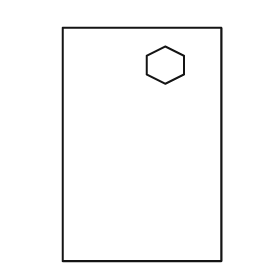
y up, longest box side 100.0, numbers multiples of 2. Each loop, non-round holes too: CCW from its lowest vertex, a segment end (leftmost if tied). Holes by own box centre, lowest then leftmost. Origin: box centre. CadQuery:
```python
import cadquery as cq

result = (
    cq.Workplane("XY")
    .moveTo(-34.0, -50.0)
    .lineTo(34.0, -50.0)
    .lineTo(34.0, 50.0)
    .lineTo(-34.0, 50.0)
    .close()
    .moveTo(10.0, 26.0)
    .lineTo(18.0, 30.0)
    .lineTo(18.0, 38.0)
    .lineTo(10.0, 42.0)
    .lineTo(2.0, 38.0)
    .lineTo(2.0, 30.0)
    .close()
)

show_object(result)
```